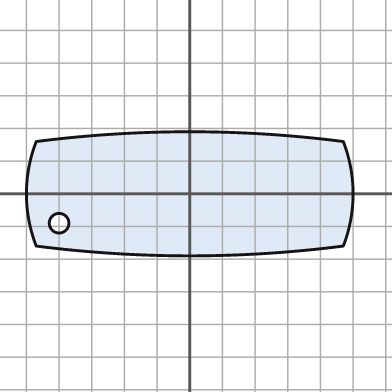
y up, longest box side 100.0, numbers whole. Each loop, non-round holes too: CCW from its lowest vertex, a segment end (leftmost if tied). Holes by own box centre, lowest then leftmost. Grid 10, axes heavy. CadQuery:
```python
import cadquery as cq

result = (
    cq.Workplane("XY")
    .moveTo(-47.0, -16.0)
    .threePointArc((0.0, -19.0), (47.0, -16.0))
    .threePointArc((50.0, 0.0), (47.0, 16.0))
    .threePointArc((0.0, 19.0), (-47.0, 16.0))
    .threePointArc((-50.0, 0.0), (-47.0, -16.0))
    .close()
    .moveTo(-40.0, -9.0)
    .circle(3.0)
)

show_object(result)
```